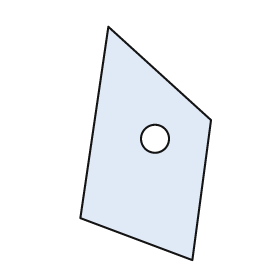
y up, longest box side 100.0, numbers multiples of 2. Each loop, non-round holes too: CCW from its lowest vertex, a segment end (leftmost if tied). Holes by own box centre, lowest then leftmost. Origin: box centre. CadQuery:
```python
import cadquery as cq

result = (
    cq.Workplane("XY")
    .moveTo(20.0, -50.0)
    .lineTo(28.0, 10.0)
    .lineTo(-16.0, 50.0)
    .lineTo(-28.0, -32.0)
    .close()
    .moveTo(4.0, 2.0)
    .circle(6.0)
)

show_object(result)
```